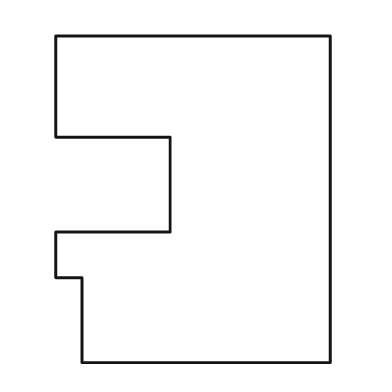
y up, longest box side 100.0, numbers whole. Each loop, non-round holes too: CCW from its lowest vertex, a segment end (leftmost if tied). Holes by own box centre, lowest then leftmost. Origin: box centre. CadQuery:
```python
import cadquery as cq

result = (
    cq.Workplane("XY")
    .moveTo(-34.0, -50.0)
    .lineTo(42.0, -50.0)
    .lineTo(42.0, 50.0)
    .lineTo(-42.0, 50.0)
    .lineTo(-42.0, 19.0)
    .lineTo(-7.0, 19.0)
    .lineTo(-7.0, -10.0)
    .lineTo(-42.0, -10.0)
    .lineTo(-42.0, -24.0)
    .lineTo(-34.0, -24.0)
    .close()
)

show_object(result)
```